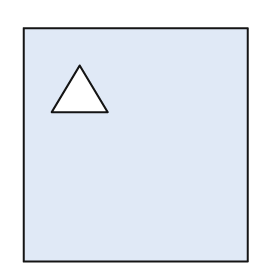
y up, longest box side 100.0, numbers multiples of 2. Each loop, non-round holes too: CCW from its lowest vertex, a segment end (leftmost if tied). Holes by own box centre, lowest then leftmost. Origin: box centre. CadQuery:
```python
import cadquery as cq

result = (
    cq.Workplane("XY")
    .moveTo(-48.0, -50.0)
    .lineTo(48.0, -50.0)
    .lineTo(48.0, 50.0)
    .lineTo(-48.0, 50.0)
    .close()
    .moveTo(-36.0, 14.0)
    .lineTo(-12.0, 14.0)
    .lineTo(-24.0, 34.0)
    .close()
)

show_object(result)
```